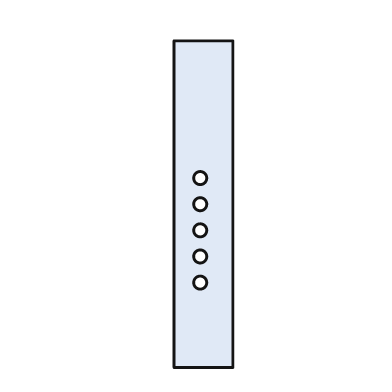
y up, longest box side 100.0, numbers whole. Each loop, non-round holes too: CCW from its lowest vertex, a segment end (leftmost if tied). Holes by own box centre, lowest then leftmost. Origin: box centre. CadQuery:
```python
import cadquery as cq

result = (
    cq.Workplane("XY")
    .moveTo(-9.0, -50.0)
    .lineTo(9.0, -50.0)
    .lineTo(9.0, 50.0)
    .lineTo(-9.0, 50.0)
    .close()
    .moveTo(-1.0, -24.0)
    .circle(2.0)
    .moveTo(-1.0, -16.0)
    .circle(2.0)
    .moveTo(-1.0, -8.0)
    .circle(2.0)
    .moveTo(-1.0, 0.0)
    .circle(2.0)
    .moveTo(-1.0, 8.0)
    .circle(2.0)
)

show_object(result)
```